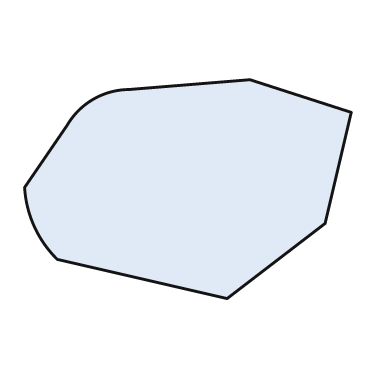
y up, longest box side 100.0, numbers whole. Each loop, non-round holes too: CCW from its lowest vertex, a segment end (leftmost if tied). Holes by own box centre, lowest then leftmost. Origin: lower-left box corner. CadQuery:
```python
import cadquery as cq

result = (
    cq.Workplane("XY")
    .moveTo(62.0, 0.0)
    .lineTo(92.0, 23.0)
    .lineTo(100.0, 57.0)
    .lineTo(69.0, 67.0)
    .lineTo(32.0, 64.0)
    .threePointArc((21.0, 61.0), (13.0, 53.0))
    .lineTo(0.0, 34.0)
    .threePointArc((3.0, 22.0), (10.0, 12.0))
    .close()
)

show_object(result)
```